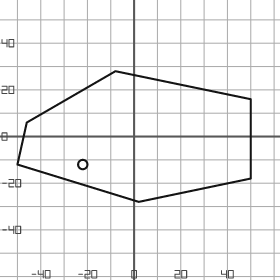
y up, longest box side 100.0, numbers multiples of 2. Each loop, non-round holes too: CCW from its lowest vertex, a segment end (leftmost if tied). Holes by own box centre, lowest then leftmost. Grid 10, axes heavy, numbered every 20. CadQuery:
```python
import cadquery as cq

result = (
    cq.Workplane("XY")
    .moveTo(2.0, -28.0)
    .lineTo(50.0, -18.0)
    .lineTo(50.0, 16.0)
    .lineTo(-8.0, 28.0)
    .lineTo(-46.0, 6.0)
    .lineTo(-50.0, -12.0)
    .close()
    .moveTo(-22.0, -12.0)
    .circle(2.0)
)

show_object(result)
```